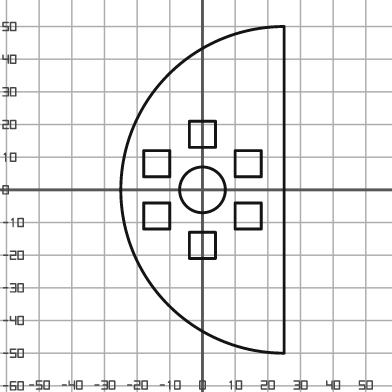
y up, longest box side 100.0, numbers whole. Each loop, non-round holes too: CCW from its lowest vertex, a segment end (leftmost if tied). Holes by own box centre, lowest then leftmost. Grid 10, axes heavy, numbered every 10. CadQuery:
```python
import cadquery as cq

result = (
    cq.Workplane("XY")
    .moveTo(25.0, -50.0)
    .lineTo(25.0, 50.0)
    .threePointArc((-25.0, 0.0), (25.0, -50.0))
    .close()
    .moveTo(-4.0, -21.0)
    .lineTo(4.0, -21.0)
    .lineTo(4.0, -13.0)
    .lineTo(-4.0, -13.0)
    .close()
    .moveTo(-18.0, -12.0)
    .lineTo(-10.0, -12.0)
    .lineTo(-10.0, -4.0)
    .lineTo(-18.0, -4.0)
    .close()
    .moveTo(10.0, -12.0)
    .lineTo(18.0, -12.0)
    .lineTo(18.0, -4.0)
    .lineTo(10.0, -4.0)
    .close()
    .moveTo(0.0, 0.0)
    .circle(7.0)
    .moveTo(-18.0, 4.0)
    .lineTo(-10.0, 4.0)
    .lineTo(-10.0, 12.0)
    .lineTo(-18.0, 12.0)
    .close()
    .moveTo(10.0, 4.0)
    .lineTo(18.0, 4.0)
    .lineTo(18.0, 12.0)
    .lineTo(10.0, 12.0)
    .close()
    .moveTo(-4.0, 13.0)
    .lineTo(4.0, 13.0)
    .lineTo(4.0, 21.0)
    .lineTo(-4.0, 21.0)
    .close()
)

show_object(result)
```